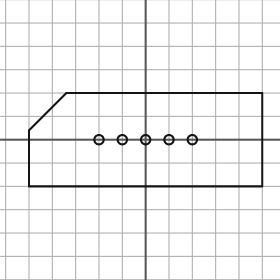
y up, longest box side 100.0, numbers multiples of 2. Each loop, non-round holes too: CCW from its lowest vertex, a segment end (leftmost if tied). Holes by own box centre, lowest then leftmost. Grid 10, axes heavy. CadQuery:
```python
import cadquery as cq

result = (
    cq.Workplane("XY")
    .moveTo(-50.0, -20.0)
    .lineTo(50.0, -20.0)
    .lineTo(50.0, 20.0)
    .lineTo(-34.0, 20.0)
    .lineTo(-50.0, 4.0)
    .close()
    .moveTo(-20.0, 0.0)
    .circle(2.0)
    .moveTo(-10.0, 0.0)
    .circle(2.0)
    .moveTo(0.0, 0.0)
    .circle(2.0)
    .moveTo(10.0, 0.0)
    .circle(2.0)
    .moveTo(20.0, 0.0)
    .circle(2.0)
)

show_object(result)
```